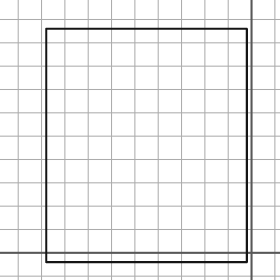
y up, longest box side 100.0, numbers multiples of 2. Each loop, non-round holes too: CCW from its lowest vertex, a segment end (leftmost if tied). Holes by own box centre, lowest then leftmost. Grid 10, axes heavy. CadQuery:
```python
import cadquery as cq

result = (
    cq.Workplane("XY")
    .moveTo(-88.0, -4.0)
    .lineTo(-2.0, -4.0)
    .lineTo(-2.0, 96.0)
    .lineTo(-88.0, 96.0)
    .close()
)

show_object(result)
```